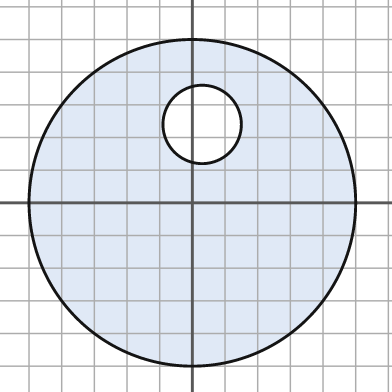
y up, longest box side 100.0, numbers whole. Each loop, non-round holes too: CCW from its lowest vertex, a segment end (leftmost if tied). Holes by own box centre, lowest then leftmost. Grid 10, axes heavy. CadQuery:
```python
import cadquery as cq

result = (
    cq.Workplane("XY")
    .moveTo(0.0, 0.0)
    .circle(50.0)
    .moveTo(3.0, 24.0)
    .circle(12.0)
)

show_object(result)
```